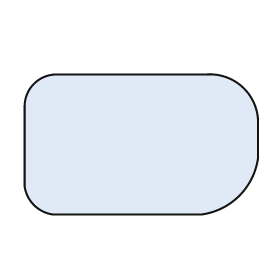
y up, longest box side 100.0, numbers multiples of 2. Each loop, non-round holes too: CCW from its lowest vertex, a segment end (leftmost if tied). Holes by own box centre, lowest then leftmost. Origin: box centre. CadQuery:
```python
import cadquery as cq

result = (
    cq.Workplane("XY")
    .moveTo(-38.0, -30.0)
    .lineTo(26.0, -30.0)
    .threePointArc((42.0, -22.0), (50.0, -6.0))
    .lineTo(50.0, 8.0)
    .threePointArc((44.0, 24.0), (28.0, 30.0))
    .lineTo(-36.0, 30.0)
    .threePointArc((-46.0, 26.0), (-50.0, 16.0))
    .lineTo(-50.0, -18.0)
    .threePointArc((-46.0, -26.0), (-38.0, -30.0))
    .close()
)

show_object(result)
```